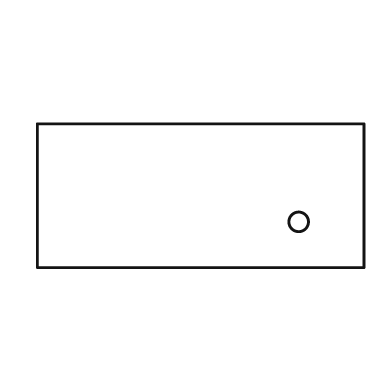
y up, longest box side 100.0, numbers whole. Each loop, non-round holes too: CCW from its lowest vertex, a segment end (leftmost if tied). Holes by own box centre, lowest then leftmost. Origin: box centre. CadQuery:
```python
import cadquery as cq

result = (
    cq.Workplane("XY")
    .moveTo(-50.0, -22.0)
    .lineTo(50.0, -22.0)
    .lineTo(50.0, 22.0)
    .lineTo(-50.0, 22.0)
    .close()
    .moveTo(30.0, -8.0)
    .circle(3.0)
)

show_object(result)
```